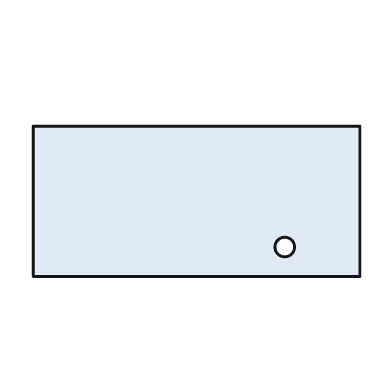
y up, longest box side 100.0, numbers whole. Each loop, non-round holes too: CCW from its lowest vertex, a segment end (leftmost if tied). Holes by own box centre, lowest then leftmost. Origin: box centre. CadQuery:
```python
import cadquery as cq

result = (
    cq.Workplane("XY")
    .moveTo(-50.0, -23.0)
    .lineTo(50.0, -23.0)
    .lineTo(50.0, 23.0)
    .lineTo(-50.0, 23.0)
    .close()
    .moveTo(27.0, -14.0)
    .circle(3.0)
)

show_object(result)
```